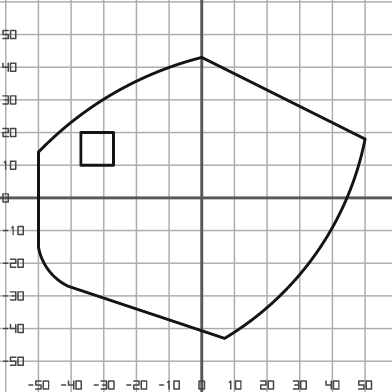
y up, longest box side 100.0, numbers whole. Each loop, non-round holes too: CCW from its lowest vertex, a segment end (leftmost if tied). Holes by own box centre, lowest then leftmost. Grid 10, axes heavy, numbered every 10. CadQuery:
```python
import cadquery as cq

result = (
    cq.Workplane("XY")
    .moveTo(7.0, -43.0)
    .threePointArc((35.0, -17.0), (50.0, 18.0))
    .lineTo(0.0, 43.0)
    .threePointArc((-27.0, 32.0), (-50.0, 14.0))
    .lineTo(-50.0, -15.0)
    .threePointArc((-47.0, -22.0), (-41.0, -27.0))
    .close()
    .moveTo(-37.0, 10.0)
    .lineTo(-27.0, 10.0)
    .lineTo(-27.0, 20.0)
    .lineTo(-37.0, 20.0)
    .close()
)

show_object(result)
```